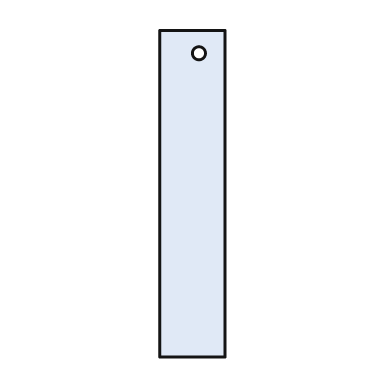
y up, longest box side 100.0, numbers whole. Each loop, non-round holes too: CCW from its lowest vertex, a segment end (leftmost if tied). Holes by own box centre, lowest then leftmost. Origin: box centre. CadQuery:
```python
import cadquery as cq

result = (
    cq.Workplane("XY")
    .moveTo(-10.0, -50.0)
    .lineTo(10.0, -50.0)
    .lineTo(10.0, 50.0)
    .lineTo(-10.0, 50.0)
    .close()
    .moveTo(2.0, 43.0)
    .circle(2.0)
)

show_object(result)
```